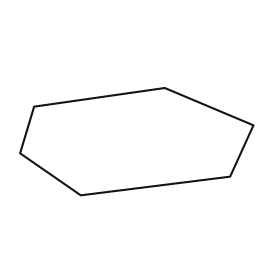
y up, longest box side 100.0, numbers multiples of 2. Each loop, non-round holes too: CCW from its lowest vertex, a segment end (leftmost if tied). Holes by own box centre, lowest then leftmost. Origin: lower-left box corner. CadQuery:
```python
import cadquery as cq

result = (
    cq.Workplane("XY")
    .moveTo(26.0, 0.0)
    .lineTo(90.0, 8.0)
    .lineTo(100.0, 30.0)
    .lineTo(62.0, 46.0)
    .lineTo(6.0, 38.0)
    .lineTo(0.0, 18.0)
    .close()
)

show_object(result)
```